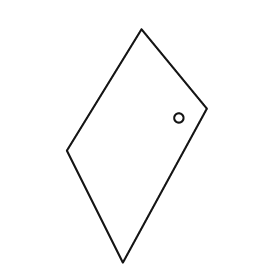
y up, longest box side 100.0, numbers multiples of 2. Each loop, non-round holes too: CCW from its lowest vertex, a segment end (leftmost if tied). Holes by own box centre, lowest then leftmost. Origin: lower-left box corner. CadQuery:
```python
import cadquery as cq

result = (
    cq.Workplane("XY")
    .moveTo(24.0, 0.0)
    .lineTo(60.0, 66.0)
    .lineTo(32.0, 100.0)
    .lineTo(0.0, 48.0)
    .close()
    .moveTo(48.0, 62.0)
    .circle(2.0)
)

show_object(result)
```